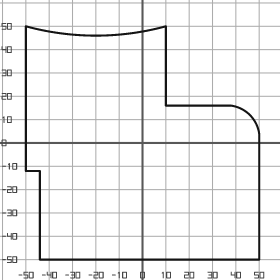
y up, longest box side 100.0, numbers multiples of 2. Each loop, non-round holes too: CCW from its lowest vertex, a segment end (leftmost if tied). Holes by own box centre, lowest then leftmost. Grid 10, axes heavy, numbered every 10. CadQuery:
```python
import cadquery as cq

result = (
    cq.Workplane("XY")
    .moveTo(-44.0, -50.0)
    .lineTo(50.0, -50.0)
    .lineTo(50.0, 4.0)
    .threePointArc((46.0, 12.0), (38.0, 16.0))
    .lineTo(10.0, 16.0)
    .lineTo(10.0, 50.0)
    .threePointArc((-20.0, 46.0), (-50.0, 50.0))
    .lineTo(-50.0, -12.0)
    .lineTo(-44.0, -12.0)
    .close()
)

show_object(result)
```